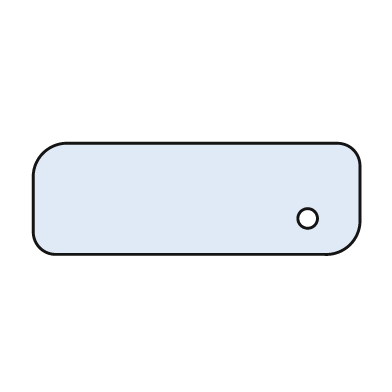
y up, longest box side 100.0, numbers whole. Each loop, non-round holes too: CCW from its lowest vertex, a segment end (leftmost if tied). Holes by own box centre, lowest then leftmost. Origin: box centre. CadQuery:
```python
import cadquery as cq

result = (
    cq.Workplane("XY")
    .moveTo(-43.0, -17.0)
    .lineTo(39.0, -17.0)
    .threePointArc((47.0, -14.0), (50.0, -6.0))
    .lineTo(50.0, 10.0)
    .threePointArc((48.0, 15.0), (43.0, 17.0))
    .lineTo(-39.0, 17.0)
    .threePointArc((-47.0, 14.0), (-50.0, 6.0))
    .lineTo(-50.0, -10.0)
    .threePointArc((-48.0, -15.0), (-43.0, -17.0))
    .close()
    .moveTo(34.0, -6.0)
    .circle(3.0)
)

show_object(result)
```